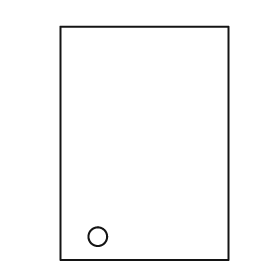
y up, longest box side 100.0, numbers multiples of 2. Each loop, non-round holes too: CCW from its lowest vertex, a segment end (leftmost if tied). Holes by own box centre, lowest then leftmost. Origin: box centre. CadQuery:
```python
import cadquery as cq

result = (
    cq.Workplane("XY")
    .moveTo(-36.0, -50.0)
    .lineTo(36.0, -50.0)
    .lineTo(36.0, 50.0)
    .lineTo(-36.0, 50.0)
    .close()
    .moveTo(-20.0, -40.0)
    .circle(4.0)
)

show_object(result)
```